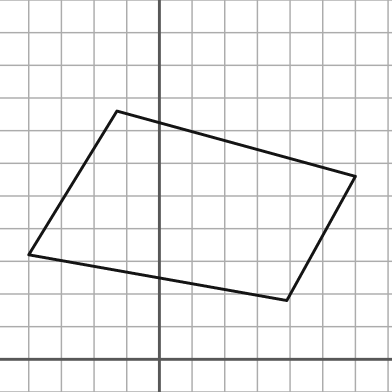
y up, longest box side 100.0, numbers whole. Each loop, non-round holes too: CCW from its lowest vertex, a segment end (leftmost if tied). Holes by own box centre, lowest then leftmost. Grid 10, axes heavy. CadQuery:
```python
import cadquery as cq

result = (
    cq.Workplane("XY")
    .moveTo(39.0, 18.0)
    .lineTo(60.0, 56.0)
    .lineTo(-13.0, 76.0)
    .lineTo(-40.0, 32.0)
    .close()
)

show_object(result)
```